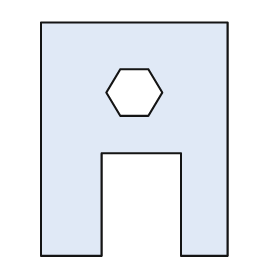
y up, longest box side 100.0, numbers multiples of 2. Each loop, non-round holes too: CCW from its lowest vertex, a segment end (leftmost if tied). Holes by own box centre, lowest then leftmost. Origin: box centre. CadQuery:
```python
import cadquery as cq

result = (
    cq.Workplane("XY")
    .moveTo(-40.0, -50.0)
    .lineTo(-14.0, -50.0)
    .lineTo(-14.0, -6.0)
    .lineTo(20.0, -6.0)
    .lineTo(20.0, -50.0)
    .lineTo(40.0, -50.0)
    .lineTo(40.0, 50.0)
    .lineTo(-40.0, 50.0)
    .close()
    .moveTo(-6.0, 10.0)
    .lineTo(6.0, 10.0)
    .lineTo(12.0, 20.0)
    .lineTo(6.0, 30.0)
    .lineTo(-6.0, 30.0)
    .lineTo(-12.0, 20.0)
    .close()
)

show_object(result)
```